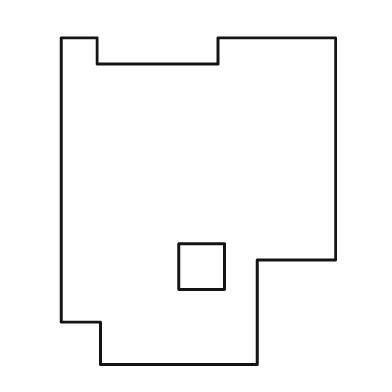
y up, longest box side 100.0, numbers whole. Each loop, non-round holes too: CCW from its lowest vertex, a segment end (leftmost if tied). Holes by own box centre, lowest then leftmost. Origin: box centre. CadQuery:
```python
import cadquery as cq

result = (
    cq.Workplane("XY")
    .moveTo(-30.0, -50.0)
    .lineTo(18.0, -50.0)
    .lineTo(18.0, -18.0)
    .lineTo(42.0, -18.0)
    .lineTo(42.0, 50.0)
    .lineTo(6.0, 50.0)
    .lineTo(6.0, 42.0)
    .lineTo(-31.0, 42.0)
    .lineTo(-31.0, 50.0)
    .lineTo(-42.0, 50.0)
    .lineTo(-42.0, -37.0)
    .lineTo(-30.0, -37.0)
    .close()
    .moveTo(-6.0, -27.0)
    .lineTo(8.0, -27.0)
    .lineTo(8.0, -13.0)
    .lineTo(-6.0, -13.0)
    .close()
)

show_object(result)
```